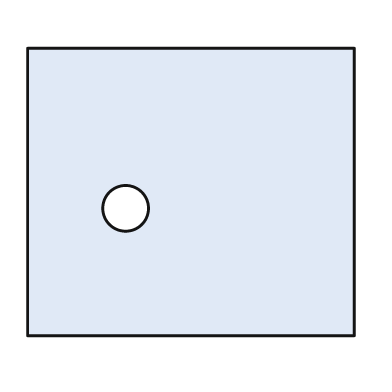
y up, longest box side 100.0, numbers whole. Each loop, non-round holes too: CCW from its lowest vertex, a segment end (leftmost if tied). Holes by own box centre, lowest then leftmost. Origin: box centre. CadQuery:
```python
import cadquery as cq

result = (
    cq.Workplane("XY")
    .moveTo(-50.0, -44.0)
    .lineTo(50.0, -44.0)
    .lineTo(50.0, 44.0)
    .lineTo(-50.0, 44.0)
    .close()
    .moveTo(-20.0, -5.0)
    .circle(7.0)
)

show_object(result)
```